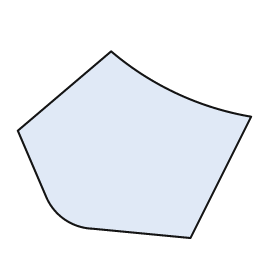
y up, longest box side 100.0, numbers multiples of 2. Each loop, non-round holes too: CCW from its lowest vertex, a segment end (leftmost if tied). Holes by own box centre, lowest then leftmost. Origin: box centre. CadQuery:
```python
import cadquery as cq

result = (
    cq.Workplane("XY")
    .moveTo(24.0, -40.0)
    .lineTo(50.0, 12.0)
    .threePointArc((18.0, 22.0), (-10.0, 40.0))
    .lineTo(-50.0, 6.0)
    .lineTo(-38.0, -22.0)
    .threePointArc((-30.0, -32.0), (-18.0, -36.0))
    .close()
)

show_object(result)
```